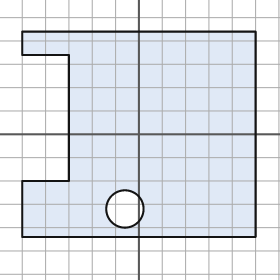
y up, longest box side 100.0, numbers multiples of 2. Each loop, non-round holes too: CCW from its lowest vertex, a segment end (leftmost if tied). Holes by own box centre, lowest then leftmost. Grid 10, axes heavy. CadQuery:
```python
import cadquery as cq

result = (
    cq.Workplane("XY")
    .moveTo(-50.0, -44.0)
    .lineTo(50.0, -44.0)
    .lineTo(50.0, 44.0)
    .lineTo(-50.0, 44.0)
    .lineTo(-50.0, 34.0)
    .lineTo(-30.0, 34.0)
    .lineTo(-30.0, -20.0)
    .lineTo(-50.0, -20.0)
    .close()
    .moveTo(-6.0, -32.0)
    .circle(8.0)
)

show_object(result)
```